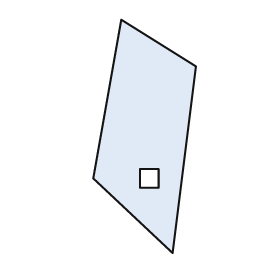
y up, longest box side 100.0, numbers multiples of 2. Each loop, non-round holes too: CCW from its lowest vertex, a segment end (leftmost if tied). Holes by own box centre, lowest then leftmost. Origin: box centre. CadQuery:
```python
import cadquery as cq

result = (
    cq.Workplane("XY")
    .moveTo(12.0, -50.0)
    .lineTo(22.0, 30.0)
    .lineTo(-10.0, 50.0)
    .lineTo(-22.0, -18.0)
    .close()
    .moveTo(-2.0, -22.0)
    .lineTo(6.0, -22.0)
    .lineTo(6.0, -14.0)
    .lineTo(-2.0, -14.0)
    .close()
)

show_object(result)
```